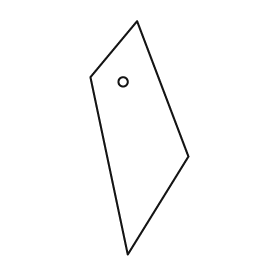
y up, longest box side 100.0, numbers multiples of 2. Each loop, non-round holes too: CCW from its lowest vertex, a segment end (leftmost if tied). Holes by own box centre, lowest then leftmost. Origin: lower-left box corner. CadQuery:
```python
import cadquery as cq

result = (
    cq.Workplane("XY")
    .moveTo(16.0, 0.0)
    .lineTo(42.0, 42.0)
    .lineTo(20.0, 100.0)
    .lineTo(0.0, 76.0)
    .close()
    .moveTo(14.0, 74.0)
    .circle(2.0)
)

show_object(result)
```